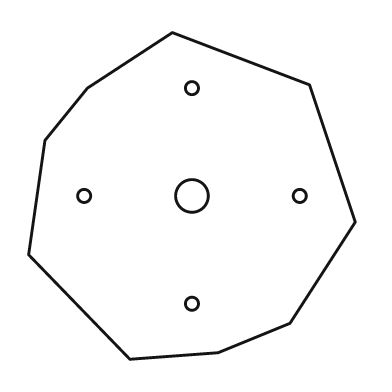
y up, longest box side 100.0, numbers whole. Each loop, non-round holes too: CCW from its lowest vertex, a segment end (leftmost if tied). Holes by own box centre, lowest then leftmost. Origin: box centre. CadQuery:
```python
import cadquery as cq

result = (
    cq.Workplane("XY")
    .moveTo(-19.0, -50.0)
    .lineTo(8.0, -48.0)
    .lineTo(30.0, -39.0)
    .lineTo(50.0, -8.0)
    .lineTo(36.0, 34.0)
    .lineTo(-6.0, 50.0)
    .lineTo(-32.0, 33.0)
    .lineTo(-45.0, 17.0)
    .lineTo(-50.0, -18.0)
    .close()
    .moveTo(0.0, -33.0)
    .circle(2.0)
    .moveTo(-33.0, 0.0)
    .circle(2.0)
    .moveTo(0.0, 0.0)
    .circle(5.0)
    .moveTo(33.0, 0.0)
    .circle(2.0)
    .moveTo(0.0, 33.0)
    .circle(2.0)
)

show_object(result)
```